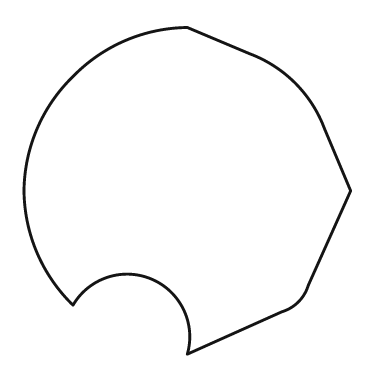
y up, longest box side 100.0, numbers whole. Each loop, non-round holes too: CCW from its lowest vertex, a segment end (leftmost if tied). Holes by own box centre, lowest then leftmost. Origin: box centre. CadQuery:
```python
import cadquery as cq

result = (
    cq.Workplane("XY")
    .moveTo(0.0, -50.0)
    .lineTo(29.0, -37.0)
    .threePointArc((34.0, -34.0), (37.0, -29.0))
    .lineTo(50.0, 0.0)
    .lineTo(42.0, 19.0)
    .threePointArc((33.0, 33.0), (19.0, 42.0))
    .lineTo(0.0, 50.0)
    .threePointArc((-19.0, 46.0), (-35.0, 35.0))
    .threePointArc((-46.0, 19.0), (-50.0, 0.0))
    .threePointArc((-46.0, -19.0), (-35.0, -35.0))
    .threePointArc((-11.0, -27.0), (0.0, -50.0))
    .close()
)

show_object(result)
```